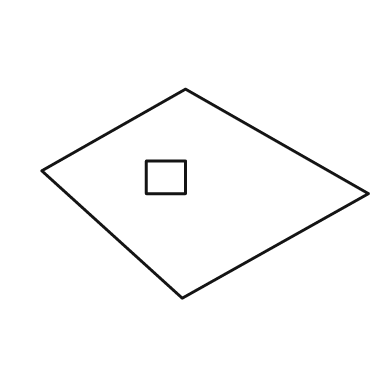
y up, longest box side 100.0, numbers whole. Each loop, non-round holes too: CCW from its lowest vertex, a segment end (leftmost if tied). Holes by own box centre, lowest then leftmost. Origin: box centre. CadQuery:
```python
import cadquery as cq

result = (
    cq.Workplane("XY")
    .moveTo(-7.0, -32.0)
    .lineTo(50.0, 0.0)
    .lineTo(-6.0, 32.0)
    .lineTo(-50.0, 7.0)
    .close()
    .moveTo(-18.0, 0.0)
    .lineTo(-6.0, 0.0)
    .lineTo(-6.0, 10.0)
    .lineTo(-18.0, 10.0)
    .close()
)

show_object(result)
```